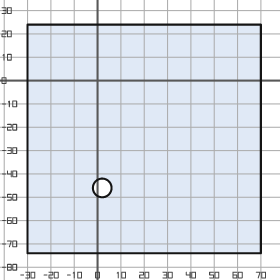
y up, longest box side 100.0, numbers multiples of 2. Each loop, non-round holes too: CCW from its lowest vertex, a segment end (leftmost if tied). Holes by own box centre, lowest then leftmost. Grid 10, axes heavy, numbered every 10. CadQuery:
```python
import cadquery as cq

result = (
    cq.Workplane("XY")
    .moveTo(-30.0, -74.0)
    .lineTo(70.0, -74.0)
    .lineTo(70.0, 24.0)
    .lineTo(-30.0, 24.0)
    .close()
    .moveTo(2.0, -46.0)
    .circle(4.0)
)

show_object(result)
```